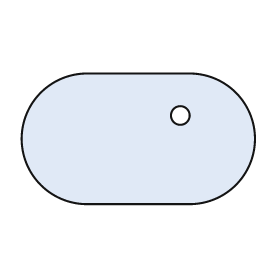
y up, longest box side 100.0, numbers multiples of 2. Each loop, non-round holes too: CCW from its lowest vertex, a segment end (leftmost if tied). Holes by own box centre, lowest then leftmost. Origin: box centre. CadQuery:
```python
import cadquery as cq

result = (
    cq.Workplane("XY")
    .moveTo(-22.0, -28.0)
    .lineTo(22.0, -28.0)
    .threePointArc((50.0, 0.0), (22.0, 28.0))
    .lineTo(-22.0, 28.0)
    .threePointArc((-50.0, 0.0), (-22.0, -28.0))
    .close()
    .moveTo(18.0, 10.0)
    .circle(4.0)
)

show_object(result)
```